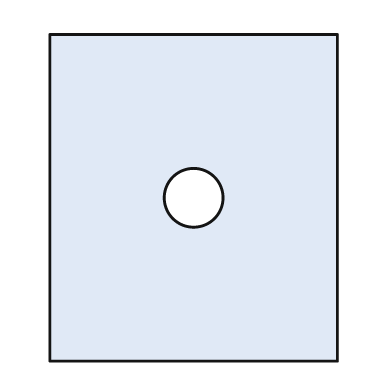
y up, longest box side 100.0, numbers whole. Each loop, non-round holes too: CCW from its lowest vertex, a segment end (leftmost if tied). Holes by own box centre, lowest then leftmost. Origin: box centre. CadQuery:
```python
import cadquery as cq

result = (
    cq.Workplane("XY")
    .moveTo(-44.0, -50.0)
    .lineTo(44.0, -50.0)
    .lineTo(44.0, 50.0)
    .lineTo(-44.0, 50.0)
    .close()
    .moveTo(0.0, 0.0)
    .circle(9.0)
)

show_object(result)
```